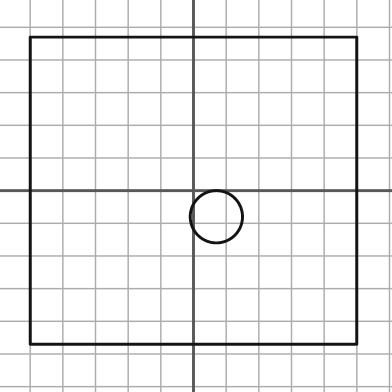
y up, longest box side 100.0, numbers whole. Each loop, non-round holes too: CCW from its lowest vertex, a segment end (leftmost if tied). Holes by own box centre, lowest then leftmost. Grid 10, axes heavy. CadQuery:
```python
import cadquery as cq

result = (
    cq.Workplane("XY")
    .moveTo(-50.0, -47.0)
    .lineTo(50.0, -47.0)
    .lineTo(50.0, 47.0)
    .lineTo(-50.0, 47.0)
    .close()
    .moveTo(7.0, -8.0)
    .circle(8.0)
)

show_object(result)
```